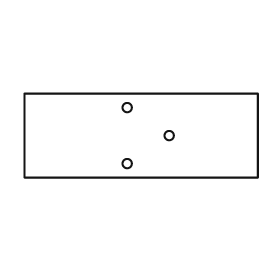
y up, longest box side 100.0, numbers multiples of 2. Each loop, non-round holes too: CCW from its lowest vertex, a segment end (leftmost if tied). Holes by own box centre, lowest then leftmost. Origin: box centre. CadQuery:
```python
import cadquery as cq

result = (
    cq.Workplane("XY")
    .moveTo(-50.0, -18.0)
    .lineTo(50.0, -18.0)
    .lineTo(50.0, 18.0)
    .lineTo(-50.0, 18.0)
    .close()
    .moveTo(-6.0, -12.0)
    .circle(2.0)
    .moveTo(12.0, 0.0)
    .circle(2.0)
    .moveTo(-6.0, 12.0)
    .circle(2.0)
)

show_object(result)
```